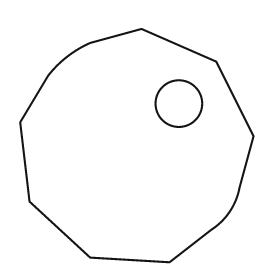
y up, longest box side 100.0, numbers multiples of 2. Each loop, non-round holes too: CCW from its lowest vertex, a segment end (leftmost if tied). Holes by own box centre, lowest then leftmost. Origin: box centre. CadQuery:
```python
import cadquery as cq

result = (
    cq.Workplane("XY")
    .moveTo(14.0, -50.0)
    .lineTo(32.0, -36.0)
    .threePointArc((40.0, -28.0), (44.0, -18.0))
    .lineTo(50.0, 4.0)
    .lineTo(34.0, 36.0)
    .lineTo(2.0, 50.0)
    .lineTo(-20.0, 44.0)
    .threePointArc((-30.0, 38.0), (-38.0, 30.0))
    .lineTo(-50.0, 10.0)
    .lineTo(-46.0, -24.0)
    .lineTo(-20.0, -48.0)
    .close()
    .moveTo(18.0, 18.0)
    .circle(10.0)
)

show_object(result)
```